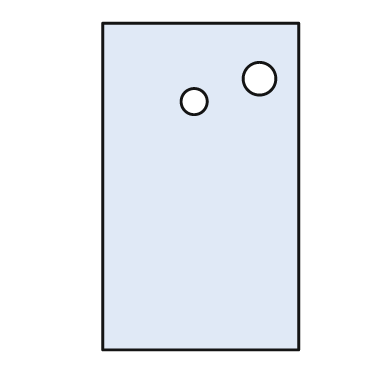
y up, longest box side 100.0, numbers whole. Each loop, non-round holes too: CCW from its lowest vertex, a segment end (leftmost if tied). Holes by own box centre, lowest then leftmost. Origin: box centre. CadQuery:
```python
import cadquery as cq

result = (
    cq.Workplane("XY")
    .moveTo(-30.0, -50.0)
    .lineTo(30.0, -50.0)
    .lineTo(30.0, 50.0)
    .lineTo(-30.0, 50.0)
    .close()
    .moveTo(-2.0, 26.0)
    .circle(4.0)
    .moveTo(18.0, 33.0)
    .circle(5.0)
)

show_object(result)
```